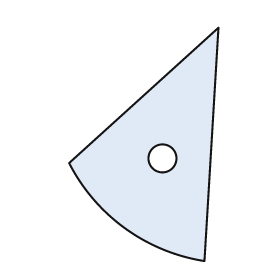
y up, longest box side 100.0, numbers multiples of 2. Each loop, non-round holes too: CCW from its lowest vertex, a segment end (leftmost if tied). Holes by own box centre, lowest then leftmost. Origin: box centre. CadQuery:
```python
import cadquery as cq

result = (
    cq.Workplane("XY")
    .moveTo(26.0, -50.0)
    .lineTo(32.0, 50.0)
    .lineTo(-32.0, -8.0)
    .threePointArc((-8.0, -36.0), (26.0, -50.0))
    .close()
    .moveTo(8.0, -6.0)
    .circle(6.0)
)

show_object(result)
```